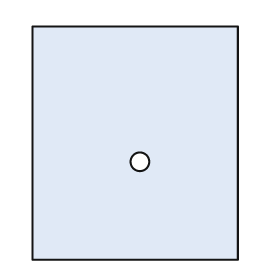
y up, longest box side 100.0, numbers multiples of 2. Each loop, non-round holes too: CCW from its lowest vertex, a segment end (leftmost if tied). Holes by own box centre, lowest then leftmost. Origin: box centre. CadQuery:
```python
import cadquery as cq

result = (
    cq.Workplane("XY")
    .moveTo(-44.0, -50.0)
    .lineTo(44.0, -50.0)
    .lineTo(44.0, 50.0)
    .lineTo(-44.0, 50.0)
    .close()
    .moveTo(2.0, -8.0)
    .circle(4.0)
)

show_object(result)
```